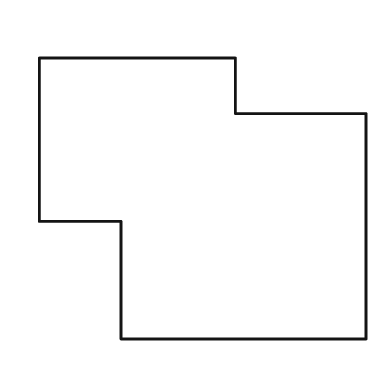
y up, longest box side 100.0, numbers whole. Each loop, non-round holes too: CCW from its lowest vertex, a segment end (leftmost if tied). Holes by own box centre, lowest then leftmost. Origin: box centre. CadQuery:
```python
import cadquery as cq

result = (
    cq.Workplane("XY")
    .moveTo(-25.0, -43.0)
    .lineTo(50.0, -43.0)
    .lineTo(50.0, 26.0)
    .lineTo(10.0, 26.0)
    .lineTo(10.0, 43.0)
    .lineTo(-50.0, 43.0)
    .lineTo(-50.0, -7.0)
    .lineTo(-25.0, -7.0)
    .close()
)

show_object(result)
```